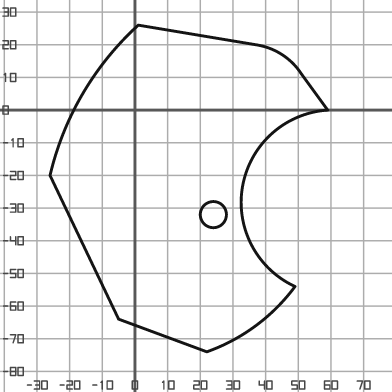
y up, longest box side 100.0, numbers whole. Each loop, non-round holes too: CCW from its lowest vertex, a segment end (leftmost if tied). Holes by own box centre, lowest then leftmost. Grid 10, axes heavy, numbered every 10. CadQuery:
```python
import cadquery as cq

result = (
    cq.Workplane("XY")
    .moveTo(22.0, -74.0)
    .threePointArc((37.0, -66.0), (49.0, -54.0))
    .threePointArc((33.0, -23.0), (59.0, 0.0))
    .lineTo(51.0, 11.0)
    .threePointArc((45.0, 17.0), (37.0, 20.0))
    .lineTo(1.0, 26.0)
    .threePointArc((-16.0, 5.0), (-26.0, -20.0))
    .lineTo(-5.0, -64.0)
    .close()
    .moveTo(24.0, -32.0)
    .circle(4.0)
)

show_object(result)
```